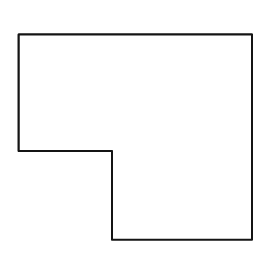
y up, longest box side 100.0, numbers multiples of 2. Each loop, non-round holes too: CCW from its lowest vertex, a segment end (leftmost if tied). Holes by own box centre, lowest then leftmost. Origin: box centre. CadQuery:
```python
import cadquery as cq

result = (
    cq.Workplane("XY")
    .moveTo(-10.0, -44.0)
    .lineTo(50.0, -44.0)
    .lineTo(50.0, 44.0)
    .lineTo(-50.0, 44.0)
    .lineTo(-50.0, -6.0)
    .lineTo(-10.0, -6.0)
    .close()
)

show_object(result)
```